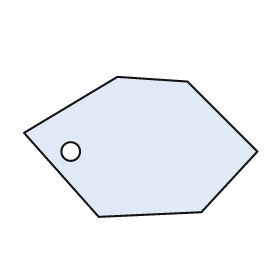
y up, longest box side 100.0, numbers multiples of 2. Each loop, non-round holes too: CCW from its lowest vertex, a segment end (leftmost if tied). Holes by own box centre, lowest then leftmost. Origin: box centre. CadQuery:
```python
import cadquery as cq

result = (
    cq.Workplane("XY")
    .moveTo(-18.0, -30.0)
    .lineTo(26.0, -28.0)
    .lineTo(50.0, -2.0)
    .lineTo(20.0, 28.0)
    .lineTo(-10.0, 30.0)
    .lineTo(-50.0, 6.0)
    .close()
    .moveTo(-30.0, -2.0)
    .circle(4.0)
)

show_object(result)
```